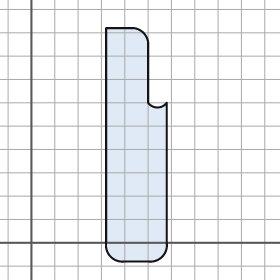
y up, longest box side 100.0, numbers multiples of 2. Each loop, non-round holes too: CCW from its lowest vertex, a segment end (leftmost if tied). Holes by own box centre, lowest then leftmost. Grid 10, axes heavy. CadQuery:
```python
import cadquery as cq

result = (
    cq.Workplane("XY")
    .moveTo(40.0, -8.0)
    .lineTo(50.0, -8.0)
    .threePointArc((56.0, -6.0), (58.0, 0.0))
    .lineTo(58.0, 60.0)
    .threePointArc((54.0, 58.0), (50.0, 60.0))
    .lineTo(50.0, 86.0)
    .threePointArc((48.0, 90.0), (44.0, 92.0))
    .lineTo(32.0, 92.0)
    .lineTo(32.0, 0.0)
    .threePointArc((34.0, -6.0), (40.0, -8.0))
    .close()
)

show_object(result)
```